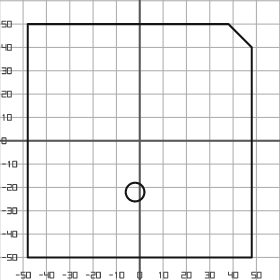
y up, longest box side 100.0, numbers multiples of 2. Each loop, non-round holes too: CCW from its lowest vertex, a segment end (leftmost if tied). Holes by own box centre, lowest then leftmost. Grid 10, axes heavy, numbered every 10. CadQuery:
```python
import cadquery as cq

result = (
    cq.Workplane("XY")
    .moveTo(-48.0, -50.0)
    .lineTo(48.0, -50.0)
    .lineTo(48.0, 40.0)
    .lineTo(38.0, 50.0)
    .lineTo(-48.0, 50.0)
    .close()
    .moveTo(-2.0, -22.0)
    .circle(4.0)
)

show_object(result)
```